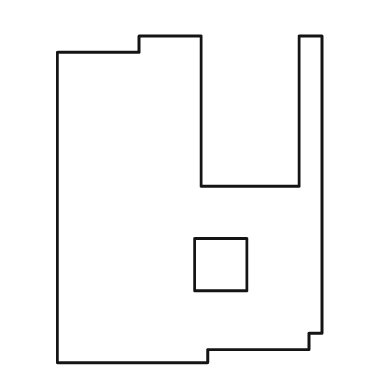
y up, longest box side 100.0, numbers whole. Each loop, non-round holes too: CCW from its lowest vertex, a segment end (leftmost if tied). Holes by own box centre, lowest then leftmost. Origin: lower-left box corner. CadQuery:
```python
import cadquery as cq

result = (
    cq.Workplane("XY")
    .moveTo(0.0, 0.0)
    .lineTo(46.0, 0.0)
    .lineTo(46.0, 4.0)
    .lineTo(77.0, 4.0)
    .lineTo(77.0, 9.0)
    .lineTo(81.0, 9.0)
    .lineTo(81.0, 100.0)
    .lineTo(74.0, 100.0)
    .lineTo(74.0, 54.0)
    .lineTo(44.0, 54.0)
    .lineTo(44.0, 100.0)
    .lineTo(25.0, 100.0)
    .lineTo(25.0, 95.0)
    .lineTo(0.0, 95.0)
    .close()
    .moveTo(42.0, 22.0)
    .lineTo(58.0, 22.0)
    .lineTo(58.0, 38.0)
    .lineTo(42.0, 38.0)
    .close()
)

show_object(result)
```